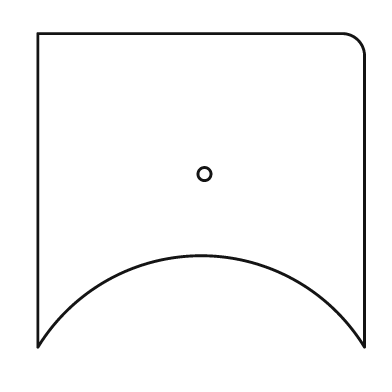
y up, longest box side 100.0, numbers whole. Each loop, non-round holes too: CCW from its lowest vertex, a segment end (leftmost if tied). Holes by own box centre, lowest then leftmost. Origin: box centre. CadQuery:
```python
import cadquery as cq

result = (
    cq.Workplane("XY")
    .moveTo(-50.0, -48.0)
    .threePointArc((0.0, -20.0), (50.0, -48.0))
    .lineTo(50.0, 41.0)
    .threePointArc((48.0, 46.0), (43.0, 48.0))
    .lineTo(-50.0, 48.0)
    .close()
    .moveTo(1.0, 5.0)
    .circle(2.0)
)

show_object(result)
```